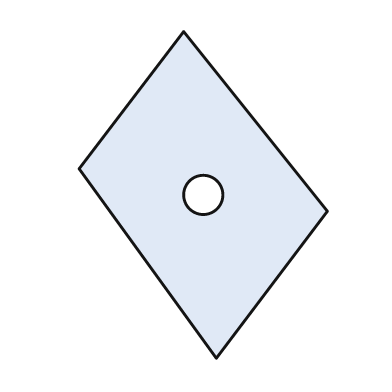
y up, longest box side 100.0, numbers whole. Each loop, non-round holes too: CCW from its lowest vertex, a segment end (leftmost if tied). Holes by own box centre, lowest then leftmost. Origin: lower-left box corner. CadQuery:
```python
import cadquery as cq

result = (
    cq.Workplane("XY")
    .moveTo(42.0, 0.0)
    .lineTo(76.0, 45.0)
    .lineTo(32.0, 100.0)
    .lineTo(0.0, 58.0)
    .close()
    .moveTo(38.0, 50.0)
    .circle(6.0)
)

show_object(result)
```